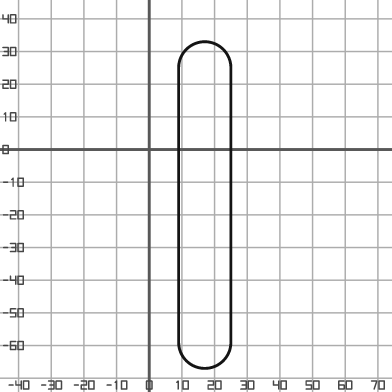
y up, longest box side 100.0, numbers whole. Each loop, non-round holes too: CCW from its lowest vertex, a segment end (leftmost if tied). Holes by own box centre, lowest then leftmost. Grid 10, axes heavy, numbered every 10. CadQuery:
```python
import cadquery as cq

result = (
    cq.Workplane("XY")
    .moveTo(9.0, -59.0)
    .threePointArc((17.0, -67.0), (25.0, -59.0))
    .lineTo(25.0, 25.0)
    .threePointArc((17.0, 33.0), (9.0, 25.0))
    .close()
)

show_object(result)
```